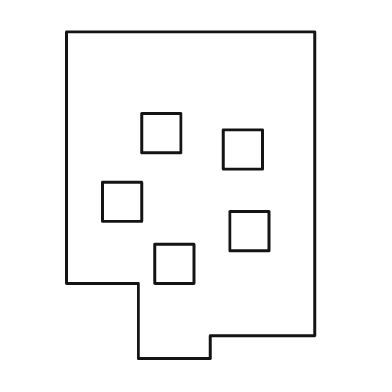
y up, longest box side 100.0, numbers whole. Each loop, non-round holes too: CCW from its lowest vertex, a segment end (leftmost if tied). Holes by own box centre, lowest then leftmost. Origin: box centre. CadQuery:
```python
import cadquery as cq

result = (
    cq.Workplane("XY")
    .moveTo(-16.0, -50.0)
    .lineTo(6.0, -50.0)
    .lineTo(6.0, -43.0)
    .lineTo(38.0, -43.0)
    .lineTo(38.0, 50.0)
    .lineTo(-38.0, 50.0)
    .lineTo(-38.0, -27.0)
    .lineTo(-16.0, -27.0)
    .close()
    .moveTo(-11.0, -27.0)
    .lineTo(1.0, -27.0)
    .lineTo(1.0, -15.0)
    .lineTo(-11.0, -15.0)
    .close()
    .moveTo(12.0, -17.0)
    .lineTo(24.0, -17.0)
    .lineTo(24.0, -5.0)
    .lineTo(12.0, -5.0)
    .close()
    .moveTo(-27.0, -8.0)
    .lineTo(-15.0, -8.0)
    .lineTo(-15.0, 4.0)
    .lineTo(-27.0, 4.0)
    .close()
    .moveTo(10.0, 8.0)
    .lineTo(22.0, 8.0)
    .lineTo(22.0, 20.0)
    .lineTo(10.0, 20.0)
    .close()
    .moveTo(-15.0, 13.0)
    .lineTo(-3.0, 13.0)
    .lineTo(-3.0, 25.0)
    .lineTo(-15.0, 25.0)
    .close()
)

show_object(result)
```